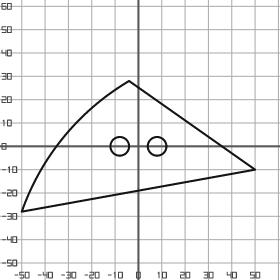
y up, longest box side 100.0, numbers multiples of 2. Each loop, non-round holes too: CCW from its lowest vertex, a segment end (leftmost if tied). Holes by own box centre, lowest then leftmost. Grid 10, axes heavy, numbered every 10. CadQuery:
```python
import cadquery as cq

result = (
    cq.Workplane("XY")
    .moveTo(-50.0, -28.0)
    .lineTo(50.0, -10.0)
    .lineTo(-4.0, 28.0)
    .threePointArc((-32.0, 4.0), (-50.0, -28.0))
    .close()
    .moveTo(-8.0, 0.0)
    .circle(4.0)
    .moveTo(8.0, 0.0)
    .circle(4.0)
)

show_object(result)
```